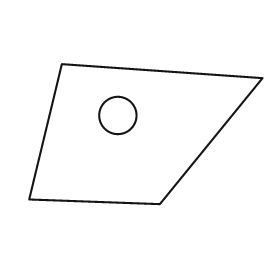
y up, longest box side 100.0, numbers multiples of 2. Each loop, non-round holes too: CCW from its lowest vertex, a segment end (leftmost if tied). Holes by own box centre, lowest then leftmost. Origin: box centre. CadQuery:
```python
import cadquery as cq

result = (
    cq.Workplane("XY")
    .moveTo(6.0, -30.0)
    .lineTo(50.0, 24.0)
    .lineTo(-36.0, 30.0)
    .lineTo(-50.0, -28.0)
    .close()
    .moveTo(-12.0, 8.0)
    .circle(8.0)
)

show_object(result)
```